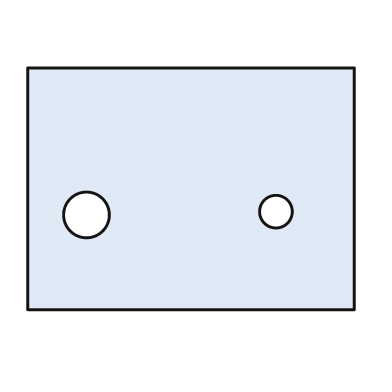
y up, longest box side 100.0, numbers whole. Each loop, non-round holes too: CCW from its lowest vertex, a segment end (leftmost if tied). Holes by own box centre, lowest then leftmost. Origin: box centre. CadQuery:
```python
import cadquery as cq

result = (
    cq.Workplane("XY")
    .moveTo(-50.0, -37.0)
    .lineTo(50.0, -37.0)
    .lineTo(50.0, 37.0)
    .lineTo(-50.0, 37.0)
    .close()
    .moveTo(-32.0, -8.0)
    .circle(7.0)
    .moveTo(26.0, -7.0)
    .circle(5.0)
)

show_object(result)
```